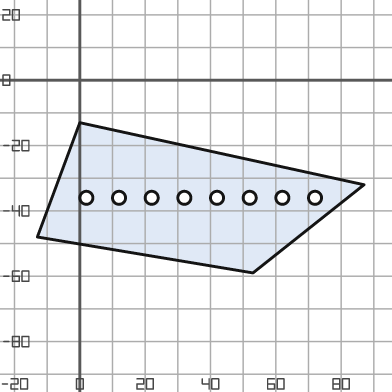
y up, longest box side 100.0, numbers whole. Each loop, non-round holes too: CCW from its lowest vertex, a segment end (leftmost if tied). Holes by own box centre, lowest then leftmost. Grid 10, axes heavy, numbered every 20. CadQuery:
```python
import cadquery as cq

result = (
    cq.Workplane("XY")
    .moveTo(53.0, -59.0)
    .lineTo(87.0, -32.0)
    .lineTo(0.0, -13.0)
    .lineTo(-13.0, -48.0)
    .close()
    .moveTo(2.0, -36.0)
    .circle(2.0)
    .moveTo(12.0, -36.0)
    .circle(2.0)
    .moveTo(22.0, -36.0)
    .circle(2.0)
    .moveTo(32.0, -36.0)
    .circle(2.0)
    .moveTo(42.0, -36.0)
    .circle(2.0)
    .moveTo(52.0, -36.0)
    .circle(2.0)
    .moveTo(62.0, -36.0)
    .circle(2.0)
    .moveTo(72.0, -36.0)
    .circle(2.0)
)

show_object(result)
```